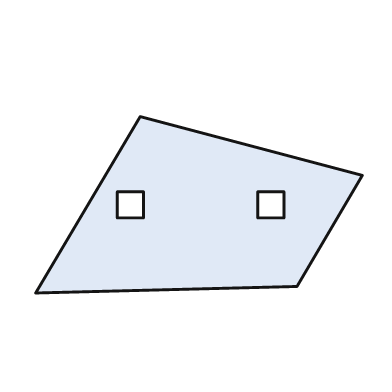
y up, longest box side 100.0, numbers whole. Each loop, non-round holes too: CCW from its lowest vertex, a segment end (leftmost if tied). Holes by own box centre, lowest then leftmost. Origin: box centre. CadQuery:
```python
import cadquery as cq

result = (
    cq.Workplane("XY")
    .moveTo(-50.0, -27.0)
    .lineTo(30.0, -25.0)
    .lineTo(50.0, 9.0)
    .lineTo(-18.0, 27.0)
    .close()
    .moveTo(-25.0, -4.0)
    .lineTo(-17.0, -4.0)
    .lineTo(-17.0, 4.0)
    .lineTo(-25.0, 4.0)
    .close()
    .moveTo(18.0, -4.0)
    .lineTo(26.0, -4.0)
    .lineTo(26.0, 4.0)
    .lineTo(18.0, 4.0)
    .close()
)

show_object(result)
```